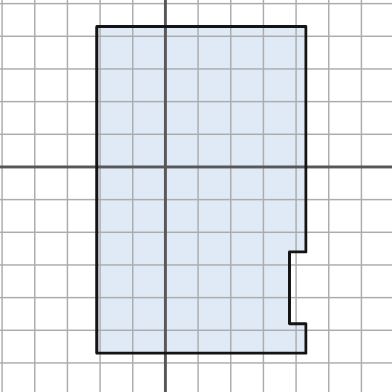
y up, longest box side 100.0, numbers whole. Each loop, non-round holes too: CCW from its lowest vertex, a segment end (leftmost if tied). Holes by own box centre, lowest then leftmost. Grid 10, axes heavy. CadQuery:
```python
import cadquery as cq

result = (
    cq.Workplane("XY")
    .moveTo(-21.0, -57.0)
    .lineTo(43.0, -57.0)
    .lineTo(43.0, -48.0)
    .lineTo(38.0, -48.0)
    .lineTo(38.0, -26.0)
    .lineTo(43.0, -26.0)
    .lineTo(43.0, 43.0)
    .lineTo(-21.0, 43.0)
    .close()
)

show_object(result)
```